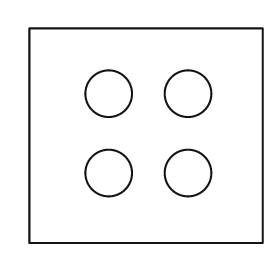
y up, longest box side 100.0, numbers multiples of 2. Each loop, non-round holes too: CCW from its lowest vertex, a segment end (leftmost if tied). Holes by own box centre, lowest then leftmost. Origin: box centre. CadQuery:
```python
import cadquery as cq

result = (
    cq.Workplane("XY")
    .moveTo(-50.0, -46.0)
    .lineTo(50.0, -46.0)
    .lineTo(50.0, 46.0)
    .lineTo(-50.0, 46.0)
    .close()
    .moveTo(-16.0, -16.0)
    .circle(10.0)
    .moveTo(18.0, -16.0)
    .circle(10.0)
    .moveTo(-16.0, 18.0)
    .circle(10.0)
    .moveTo(18.0, 18.0)
    .circle(10.0)
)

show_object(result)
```